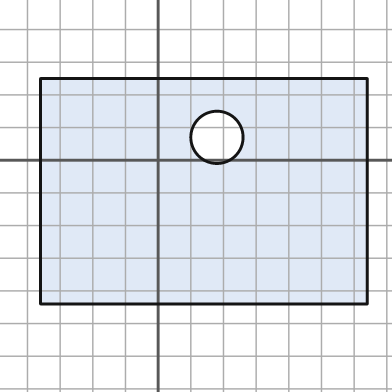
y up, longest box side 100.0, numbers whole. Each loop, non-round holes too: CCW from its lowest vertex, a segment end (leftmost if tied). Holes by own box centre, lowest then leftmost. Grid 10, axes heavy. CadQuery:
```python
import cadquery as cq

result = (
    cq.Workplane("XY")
    .moveTo(-36.0, -44.0)
    .lineTo(64.0, -44.0)
    .lineTo(64.0, 25.0)
    .lineTo(-36.0, 25.0)
    .close()
    .moveTo(18.0, 7.0)
    .circle(8.0)
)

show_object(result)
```